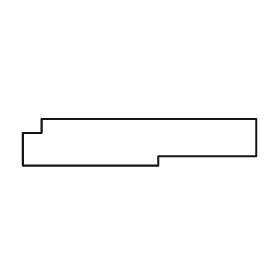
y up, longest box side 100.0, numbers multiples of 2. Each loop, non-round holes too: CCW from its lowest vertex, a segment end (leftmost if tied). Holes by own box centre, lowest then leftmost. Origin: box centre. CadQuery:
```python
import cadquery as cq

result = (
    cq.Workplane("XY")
    .moveTo(-50.0, -10.0)
    .lineTo(8.0, -10.0)
    .lineTo(8.0, -6.0)
    .lineTo(50.0, -6.0)
    .lineTo(50.0, 10.0)
    .lineTo(-42.0, 10.0)
    .lineTo(-42.0, 4.0)
    .lineTo(-50.0, 4.0)
    .close()
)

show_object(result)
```